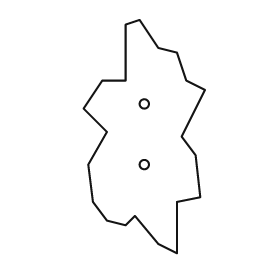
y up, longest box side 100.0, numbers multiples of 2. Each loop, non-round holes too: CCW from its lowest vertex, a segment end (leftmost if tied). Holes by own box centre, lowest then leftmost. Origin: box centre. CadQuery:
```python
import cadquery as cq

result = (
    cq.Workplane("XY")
    .moveTo(14.0, -50.0)
    .lineTo(14.0, -28.0)
    .lineTo(24.0, -26.0)
    .lineTo(22.0, -8.0)
    .lineTo(16.0, 0.0)
    .lineTo(26.0, 20.0)
    .lineTo(18.0, 24.0)
    .lineTo(14.0, 36.0)
    .lineTo(6.0, 38.0)
    .lineTo(-2.0, 50.0)
    .lineTo(-8.0, 48.0)
    .lineTo(-8.0, 24.0)
    .lineTo(-18.0, 24.0)
    .lineTo(-26.0, 12.0)
    .lineTo(-16.0, 2.0)
    .lineTo(-24.0, -12.0)
    .lineTo(-22.0, -28.0)
    .lineTo(-16.0, -36.0)
    .lineTo(-8.0, -38.0)
    .lineTo(-4.0, -34.0)
    .lineTo(6.0, -46.0)
    .close()
    .moveTo(0.0, -12.0)
    .circle(2.0)
    .moveTo(0.0, 14.0)
    .circle(2.0)
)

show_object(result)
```